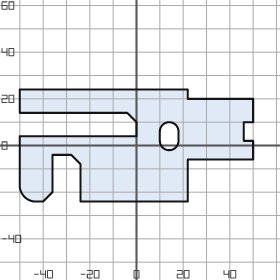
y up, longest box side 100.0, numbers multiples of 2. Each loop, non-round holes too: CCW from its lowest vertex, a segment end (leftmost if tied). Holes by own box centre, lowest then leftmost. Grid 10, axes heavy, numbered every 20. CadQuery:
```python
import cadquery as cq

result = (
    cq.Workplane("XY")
    .moveTo(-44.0, -24.0)
    .lineTo(-40.0, -24.0)
    .lineTo(-36.0, -20.0)
    .lineTo(-36.0, -4.0)
    .lineTo(-28.0, -4.0)
    .lineTo(-24.0, -8.0)
    .lineTo(-24.0, -24.0)
    .lineTo(22.0, -24.0)
    .lineTo(22.0, -6.0)
    .lineTo(50.0, -6.0)
    .lineTo(50.0, 2.0)
    .lineTo(46.0, 2.0)
    .lineTo(46.0, 10.0)
    .lineTo(50.0, 10.0)
    .lineTo(50.0, 20.0)
    .lineTo(22.0, 20.0)
    .lineTo(22.0, 24.0)
    .lineTo(-50.0, 24.0)
    .lineTo(-50.0, 14.0)
    .lineTo(-4.0, 14.0)
    .lineTo(0.0, 10.0)
    .lineTo(0.0, 4.0)
    .lineTo(-50.0, 4.0)
    .lineTo(-50.0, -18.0)
    .threePointArc((-48.0, -22.0), (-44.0, -24.0))
    .close()
    .moveTo(10.0, 2.0)
    .threePointArc((14.0, -2.0), (18.0, 2.0))
    .lineTo(18.0, 6.0)
    .threePointArc((14.0, 10.0), (10.0, 6.0))
    .close()
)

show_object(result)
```